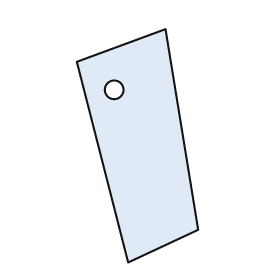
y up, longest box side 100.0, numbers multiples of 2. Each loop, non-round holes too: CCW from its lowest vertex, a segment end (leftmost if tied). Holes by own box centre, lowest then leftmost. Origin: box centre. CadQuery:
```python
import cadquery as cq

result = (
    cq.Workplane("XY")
    .moveTo(-4.0, -50.0)
    .lineTo(26.0, -36.0)
    .lineTo(12.0, 50.0)
    .lineTo(-26.0, 36.0)
    .close()
    .moveTo(-10.0, 24.0)
    .circle(4.0)
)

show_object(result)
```